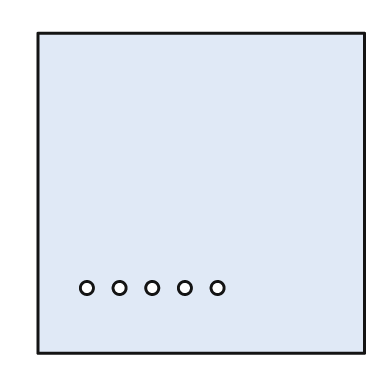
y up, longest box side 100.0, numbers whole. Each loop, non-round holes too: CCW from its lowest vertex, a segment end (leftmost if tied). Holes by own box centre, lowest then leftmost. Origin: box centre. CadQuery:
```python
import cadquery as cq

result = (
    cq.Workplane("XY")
    .moveTo(-50.0, -49.0)
    .lineTo(50.0, -49.0)
    .lineTo(50.0, 49.0)
    .lineTo(-50.0, 49.0)
    .close()
    .moveTo(-35.0, -29.0)
    .circle(2.0)
    .moveTo(-25.0, -29.0)
    .circle(2.0)
    .moveTo(-15.0, -29.0)
    .circle(2.0)
    .moveTo(-5.0, -29.0)
    .circle(2.0)
    .moveTo(5.0, -29.0)
    .circle(2.0)
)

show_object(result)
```